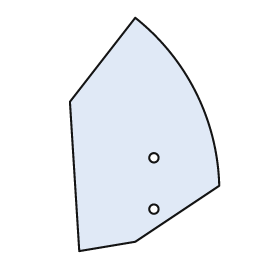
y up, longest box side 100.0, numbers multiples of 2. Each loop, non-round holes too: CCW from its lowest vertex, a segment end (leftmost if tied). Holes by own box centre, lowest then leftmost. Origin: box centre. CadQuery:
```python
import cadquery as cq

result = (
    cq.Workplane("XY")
    .moveTo(-28.0, -50.0)
    .lineTo(-4.0, -46.0)
    .lineTo(32.0, -22.0)
    .threePointArc((22.0, 18.0), (-4.0, 50.0))
    .lineTo(-32.0, 14.0)
    .close()
    .moveTo(4.0, -32.0)
    .circle(2.0)
    .moveTo(4.0, -10.0)
    .circle(2.0)
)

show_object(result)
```